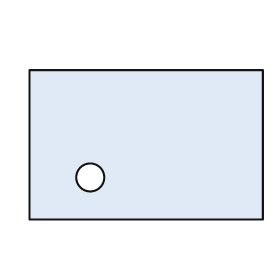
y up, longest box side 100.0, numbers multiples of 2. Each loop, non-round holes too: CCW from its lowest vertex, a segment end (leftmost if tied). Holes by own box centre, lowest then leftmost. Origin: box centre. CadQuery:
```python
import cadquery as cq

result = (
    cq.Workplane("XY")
    .moveTo(-50.0, -32.0)
    .lineTo(50.0, -32.0)
    .lineTo(50.0, 32.0)
    .lineTo(-50.0, 32.0)
    .close()
    .moveTo(-24.0, -14.0)
    .circle(6.0)
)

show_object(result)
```